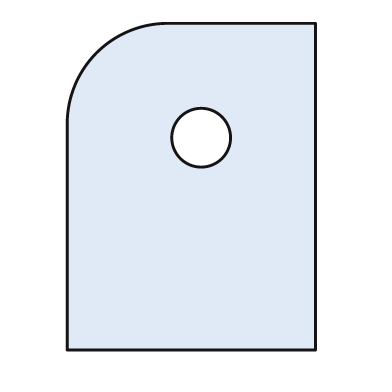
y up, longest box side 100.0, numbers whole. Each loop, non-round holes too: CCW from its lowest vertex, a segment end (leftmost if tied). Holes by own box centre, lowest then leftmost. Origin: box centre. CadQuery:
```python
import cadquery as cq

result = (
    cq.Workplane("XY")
    .moveTo(-38.0, -50.0)
    .lineTo(38.0, -50.0)
    .lineTo(38.0, 50.0)
    .lineTo(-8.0, 50.0)
    .threePointArc((-29.0, 41.0), (-38.0, 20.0))
    .close()
    .moveTo(3.0, 15.0)
    .circle(9.0)
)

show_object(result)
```